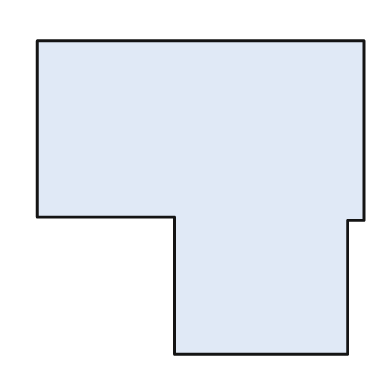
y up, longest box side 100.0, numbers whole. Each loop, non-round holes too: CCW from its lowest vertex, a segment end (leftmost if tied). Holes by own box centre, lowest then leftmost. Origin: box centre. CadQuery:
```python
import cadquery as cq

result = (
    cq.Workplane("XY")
    .moveTo(-8.0, -48.0)
    .lineTo(45.0, -48.0)
    .lineTo(45.0, -7.0)
    .lineTo(50.0, -7.0)
    .lineTo(50.0, 48.0)
    .lineTo(-50.0, 48.0)
    .lineTo(-50.0, -6.0)
    .lineTo(-8.0, -6.0)
    .close()
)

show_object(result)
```